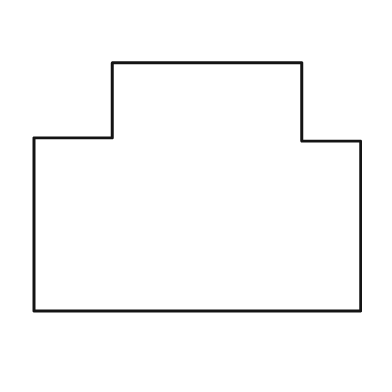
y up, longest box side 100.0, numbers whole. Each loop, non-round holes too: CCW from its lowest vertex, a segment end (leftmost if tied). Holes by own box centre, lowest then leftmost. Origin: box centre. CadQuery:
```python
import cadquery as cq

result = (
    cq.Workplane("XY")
    .moveTo(-50.0, -38.0)
    .lineTo(50.0, -38.0)
    .lineTo(50.0, 14.0)
    .lineTo(32.0, 14.0)
    .lineTo(32.0, 38.0)
    .lineTo(-26.0, 38.0)
    .lineTo(-26.0, 15.0)
    .lineTo(-50.0, 15.0)
    .close()
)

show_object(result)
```